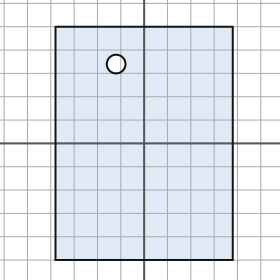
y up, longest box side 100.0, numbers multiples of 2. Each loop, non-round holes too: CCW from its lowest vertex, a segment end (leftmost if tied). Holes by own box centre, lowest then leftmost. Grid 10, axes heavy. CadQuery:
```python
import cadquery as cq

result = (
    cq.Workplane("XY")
    .moveTo(-38.0, -50.0)
    .lineTo(38.0, -50.0)
    .lineTo(38.0, 50.0)
    .lineTo(-38.0, 50.0)
    .close()
    .moveTo(-12.0, 34.0)
    .circle(4.0)
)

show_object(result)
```